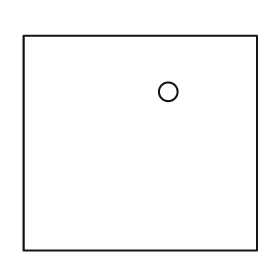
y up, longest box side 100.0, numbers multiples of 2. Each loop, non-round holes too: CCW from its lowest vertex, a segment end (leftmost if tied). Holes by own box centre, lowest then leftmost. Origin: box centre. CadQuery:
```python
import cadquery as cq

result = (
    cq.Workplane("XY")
    .moveTo(-50.0, -46.0)
    .lineTo(50.0, -46.0)
    .lineTo(50.0, 46.0)
    .lineTo(-50.0, 46.0)
    .close()
    .moveTo(12.0, 22.0)
    .circle(4.0)
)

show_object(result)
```